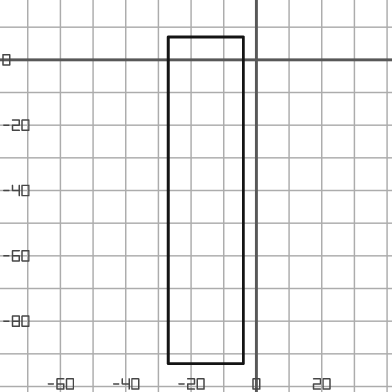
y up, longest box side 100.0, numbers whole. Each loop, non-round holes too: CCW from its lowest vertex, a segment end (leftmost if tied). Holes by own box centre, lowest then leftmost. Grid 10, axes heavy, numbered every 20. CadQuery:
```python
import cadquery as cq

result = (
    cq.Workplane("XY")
    .moveTo(-27.0, -93.0)
    .lineTo(-4.0, -93.0)
    .lineTo(-4.0, 7.0)
    .lineTo(-27.0, 7.0)
    .close()
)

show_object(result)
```